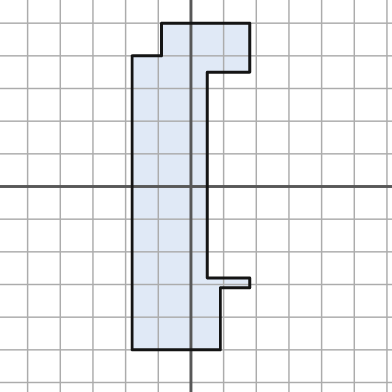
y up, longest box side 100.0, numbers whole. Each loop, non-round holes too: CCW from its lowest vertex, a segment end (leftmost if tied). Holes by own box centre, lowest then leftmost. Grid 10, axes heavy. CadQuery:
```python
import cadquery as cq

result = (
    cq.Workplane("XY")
    .moveTo(-18.0, -50.0)
    .lineTo(9.0, -50.0)
    .lineTo(9.0, -31.0)
    .lineTo(18.0, -31.0)
    .lineTo(18.0, -28.0)
    .lineTo(5.0, -28.0)
    .lineTo(5.0, 35.0)
    .lineTo(18.0, 35.0)
    .lineTo(18.0, 50.0)
    .lineTo(-9.0, 50.0)
    .lineTo(-9.0, 40.0)
    .lineTo(-18.0, 40.0)
    .close()
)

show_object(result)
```